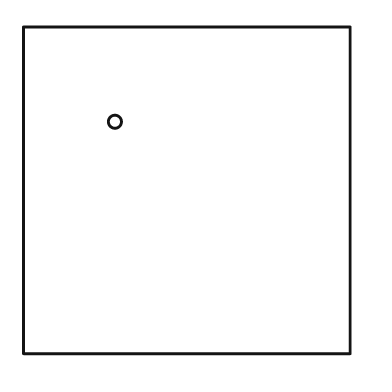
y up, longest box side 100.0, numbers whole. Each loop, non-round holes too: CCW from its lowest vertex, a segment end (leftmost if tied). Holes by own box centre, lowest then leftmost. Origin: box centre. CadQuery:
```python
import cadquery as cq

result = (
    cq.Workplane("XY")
    .moveTo(-50.0, -50.0)
    .lineTo(50.0, -50.0)
    .lineTo(50.0, 50.0)
    .lineTo(-50.0, 50.0)
    .close()
    .moveTo(-22.0, 21.0)
    .circle(2.0)
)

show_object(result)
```